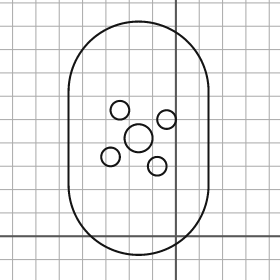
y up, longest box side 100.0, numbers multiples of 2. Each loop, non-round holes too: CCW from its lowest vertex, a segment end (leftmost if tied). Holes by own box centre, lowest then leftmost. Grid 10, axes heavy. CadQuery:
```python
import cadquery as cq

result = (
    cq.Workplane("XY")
    .moveTo(-46.0, 22.0)
    .threePointArc((-16.0, -8.0), (14.0, 22.0))
    .lineTo(14.0, 62.0)
    .threePointArc((-16.0, 92.0), (-46.0, 62.0))
    .close()
    .moveTo(-8.0, 30.0)
    .circle(4.0)
    .moveTo(-28.0, 34.0)
    .circle(4.0)
    .moveTo(-16.0, 42.0)
    .circle(6.0)
    .moveTo(-4.0, 50.0)
    .circle(4.0)
    .moveTo(-24.0, 54.0)
    .circle(4.0)
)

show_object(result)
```